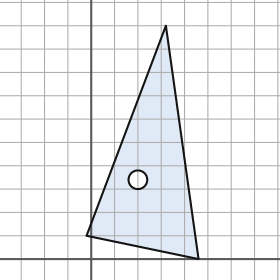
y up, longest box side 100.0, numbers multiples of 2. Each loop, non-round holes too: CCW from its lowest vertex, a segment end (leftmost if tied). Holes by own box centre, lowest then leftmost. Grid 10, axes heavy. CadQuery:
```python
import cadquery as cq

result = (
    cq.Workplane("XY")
    .moveTo(46.0, 0.0)
    .lineTo(32.0, 100.0)
    .lineTo(-2.0, 10.0)
    .close()
    .moveTo(20.0, 34.0)
    .circle(4.0)
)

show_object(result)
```